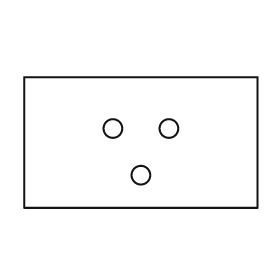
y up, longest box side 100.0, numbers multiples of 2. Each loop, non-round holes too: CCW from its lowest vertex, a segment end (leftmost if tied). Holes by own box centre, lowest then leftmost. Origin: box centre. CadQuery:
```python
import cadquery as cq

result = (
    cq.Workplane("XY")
    .moveTo(-50.0, -28.0)
    .lineTo(50.0, -28.0)
    .lineTo(50.0, 28.0)
    .lineTo(-50.0, 28.0)
    .close()
    .moveTo(0.0, -14.0)
    .circle(4.0)
    .moveTo(-12.0, 6.0)
    .circle(4.0)
    .moveTo(12.0, 6.0)
    .circle(4.0)
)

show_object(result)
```